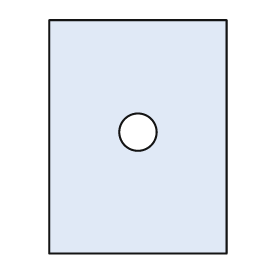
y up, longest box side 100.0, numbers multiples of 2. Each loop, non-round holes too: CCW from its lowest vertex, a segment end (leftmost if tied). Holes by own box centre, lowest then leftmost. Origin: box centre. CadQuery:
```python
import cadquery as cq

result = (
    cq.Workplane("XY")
    .moveTo(-38.0, -50.0)
    .lineTo(38.0, -50.0)
    .lineTo(38.0, 50.0)
    .lineTo(-38.0, 50.0)
    .close()
    .moveTo(0.0, 2.0)
    .circle(8.0)
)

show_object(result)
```